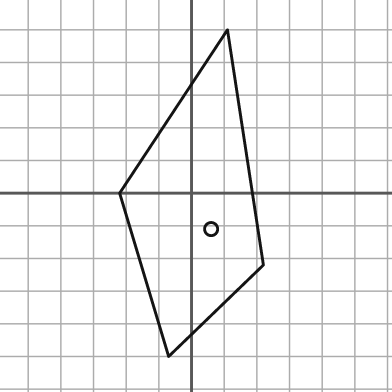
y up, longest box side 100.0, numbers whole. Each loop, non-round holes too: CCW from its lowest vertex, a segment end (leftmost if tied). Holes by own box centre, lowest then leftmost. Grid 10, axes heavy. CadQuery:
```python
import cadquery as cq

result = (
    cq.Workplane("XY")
    .moveTo(-7.0, -50.0)
    .lineTo(22.0, -22.0)
    .lineTo(11.0, 50.0)
    .lineTo(-22.0, 0.0)
    .close()
    .moveTo(6.0, -11.0)
    .circle(2.0)
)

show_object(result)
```